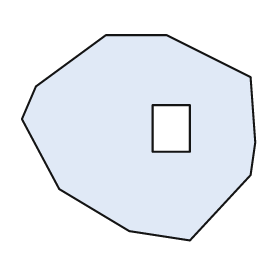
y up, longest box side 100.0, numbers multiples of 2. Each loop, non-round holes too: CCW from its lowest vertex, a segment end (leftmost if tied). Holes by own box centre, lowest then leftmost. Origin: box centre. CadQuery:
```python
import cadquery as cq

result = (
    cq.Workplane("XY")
    .moveTo(22.0, -44.0)
    .lineTo(48.0, -16.0)
    .lineTo(50.0, -2.0)
    .lineTo(48.0, 26.0)
    .lineTo(12.0, 44.0)
    .lineTo(-14.0, 44.0)
    .lineTo(-44.0, 22.0)
    .lineTo(-50.0, 8.0)
    .lineTo(-34.0, -22.0)
    .lineTo(-4.0, -40.0)
    .close()
    .moveTo(6.0, -6.0)
    .lineTo(22.0, -6.0)
    .lineTo(22.0, 14.0)
    .lineTo(6.0, 14.0)
    .close()
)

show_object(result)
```